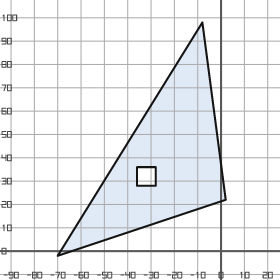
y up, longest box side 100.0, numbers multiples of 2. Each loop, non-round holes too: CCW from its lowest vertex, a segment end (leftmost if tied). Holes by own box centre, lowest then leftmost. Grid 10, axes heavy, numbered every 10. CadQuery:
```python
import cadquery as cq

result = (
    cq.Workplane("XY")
    .moveTo(-70.0, -2.0)
    .lineTo(2.0, 22.0)
    .lineTo(-8.0, 98.0)
    .close()
    .moveTo(-36.0, 28.0)
    .lineTo(-28.0, 28.0)
    .lineTo(-28.0, 36.0)
    .lineTo(-36.0, 36.0)
    .close()
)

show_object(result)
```